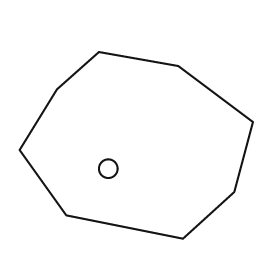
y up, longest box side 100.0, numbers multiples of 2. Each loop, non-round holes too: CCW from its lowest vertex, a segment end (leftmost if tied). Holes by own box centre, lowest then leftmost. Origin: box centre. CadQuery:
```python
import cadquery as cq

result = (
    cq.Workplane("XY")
    .moveTo(20.0, -40.0)
    .lineTo(42.0, -20.0)
    .lineTo(50.0, 10.0)
    .lineTo(18.0, 34.0)
    .lineTo(-16.0, 40.0)
    .lineTo(-34.0, 24.0)
    .lineTo(-50.0, -2.0)
    .lineTo(-30.0, -30.0)
    .close()
    .moveTo(-12.0, -10.0)
    .circle(4.0)
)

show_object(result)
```